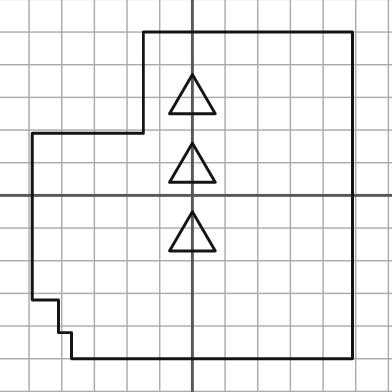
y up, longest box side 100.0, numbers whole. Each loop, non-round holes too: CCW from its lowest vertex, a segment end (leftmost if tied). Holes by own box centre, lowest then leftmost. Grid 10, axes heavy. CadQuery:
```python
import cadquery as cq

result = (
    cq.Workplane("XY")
    .moveTo(-37.0, -50.0)
    .lineTo(49.0, -50.0)
    .lineTo(49.0, 50.0)
    .lineTo(-15.0, 50.0)
    .lineTo(-15.0, 19.0)
    .lineTo(-49.0, 19.0)
    .lineTo(-49.0, -32.0)
    .lineTo(-41.0, -32.0)
    .lineTo(-41.0, -42.0)
    .lineTo(-37.0, -42.0)
    .close()
    .moveTo(-7.0, -17.0)
    .lineTo(7.0, -17.0)
    .lineTo(0.0, -5.0)
    .close()
    .moveTo(-7.0, 4.0)
    .lineTo(7.0, 4.0)
    .lineTo(0.0, 16.0)
    .close()
    .moveTo(-7.0, 25.0)
    .lineTo(7.0, 25.0)
    .lineTo(0.0, 37.0)
    .close()
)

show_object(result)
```